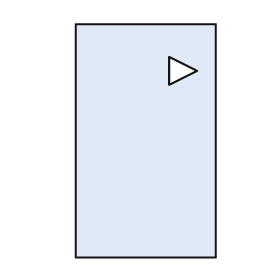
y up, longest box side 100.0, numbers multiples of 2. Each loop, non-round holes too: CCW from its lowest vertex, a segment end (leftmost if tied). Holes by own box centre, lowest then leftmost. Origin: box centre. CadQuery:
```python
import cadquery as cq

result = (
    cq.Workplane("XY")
    .moveTo(-30.0, -50.0)
    .lineTo(30.0, -50.0)
    .lineTo(30.0, 50.0)
    .lineTo(-30.0, 50.0)
    .close()
    .moveTo(10.0, 24.0)
    .lineTo(22.0, 30.0)
    .lineTo(10.0, 36.0)
    .close()
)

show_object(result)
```